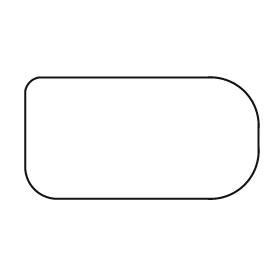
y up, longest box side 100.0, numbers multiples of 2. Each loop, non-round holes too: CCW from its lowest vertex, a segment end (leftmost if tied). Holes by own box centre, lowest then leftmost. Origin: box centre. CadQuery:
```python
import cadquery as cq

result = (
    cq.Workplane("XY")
    .moveTo(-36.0, -26.0)
    .lineTo(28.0, -26.0)
    .threePointArc((44.0, -20.0), (50.0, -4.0))
    .lineTo(50.0, 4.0)
    .threePointArc((44.0, 20.0), (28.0, 26.0))
    .lineTo(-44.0, 26.0)
    .threePointArc((-48.0, 24.0), (-50.0, 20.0))
    .lineTo(-50.0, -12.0)
    .threePointArc((-46.0, -22.0), (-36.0, -26.0))
    .close()
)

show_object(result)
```